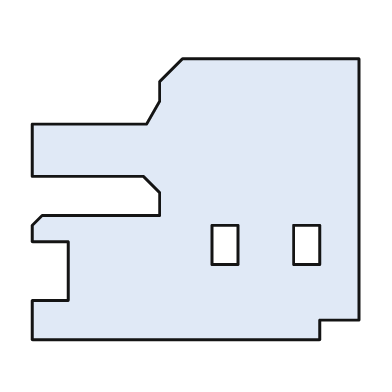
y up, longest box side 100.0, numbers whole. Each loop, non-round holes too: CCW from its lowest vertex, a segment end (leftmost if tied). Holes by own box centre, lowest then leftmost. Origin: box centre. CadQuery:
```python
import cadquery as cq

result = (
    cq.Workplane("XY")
    .moveTo(-50.0, -43.0)
    .lineTo(38.0, -43.0)
    .lineTo(38.0, -37.0)
    .lineTo(50.0, -37.0)
    .lineTo(50.0, 43.0)
    .lineTo(-4.0, 43.0)
    .lineTo(-11.0, 36.0)
    .lineTo(-11.0, 30.0)
    .lineTo(-15.0, 23.0)
    .lineTo(-50.0, 23.0)
    .lineTo(-50.0, 7.0)
    .lineTo(-16.0, 7.0)
    .lineTo(-11.0, 2.0)
    .lineTo(-11.0, -5.0)
    .lineTo(-47.0, -5.0)
    .lineTo(-50.0, -8.0)
    .lineTo(-50.0, -13.0)
    .lineTo(-39.0, -13.0)
    .lineTo(-39.0, -31.0)
    .lineTo(-50.0, -31.0)
    .close()
    .moveTo(5.0, -20.0)
    .lineTo(13.0, -20.0)
    .lineTo(13.0, -8.0)
    .lineTo(5.0, -8.0)
    .close()
    .moveTo(30.0, -20.0)
    .lineTo(38.0, -20.0)
    .lineTo(38.0, -8.0)
    .lineTo(30.0, -8.0)
    .close()
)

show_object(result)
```